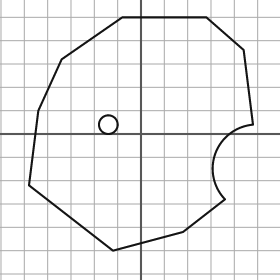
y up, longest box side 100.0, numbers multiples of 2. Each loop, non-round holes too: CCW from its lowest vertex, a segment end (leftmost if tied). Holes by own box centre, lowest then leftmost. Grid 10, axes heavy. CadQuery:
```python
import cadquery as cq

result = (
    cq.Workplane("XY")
    .moveTo(-12.0, -50.0)
    .lineTo(18.0, -42.0)
    .lineTo(36.0, -28.0)
    .threePointArc((32.0, -8.0), (48.0, 4.0))
    .lineTo(44.0, 36.0)
    .lineTo(28.0, 50.0)
    .lineTo(-8.0, 50.0)
    .lineTo(-34.0, 32.0)
    .lineTo(-44.0, 10.0)
    .lineTo(-48.0, -22.0)
    .close()
    .moveTo(-14.0, 4.0)
    .circle(4.0)
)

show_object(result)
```